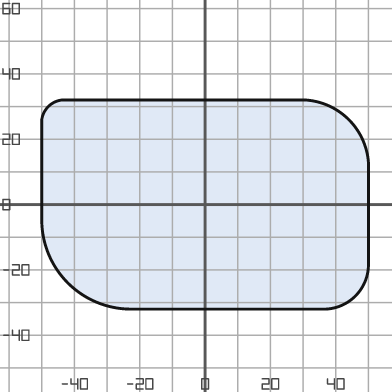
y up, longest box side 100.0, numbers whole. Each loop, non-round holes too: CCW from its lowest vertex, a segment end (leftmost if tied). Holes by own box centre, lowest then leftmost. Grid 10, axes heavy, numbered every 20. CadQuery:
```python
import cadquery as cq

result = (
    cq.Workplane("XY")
    .moveTo(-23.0, -32.0)
    .lineTo(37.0, -32.0)
    .threePointArc((46.0, -28.0), (50.0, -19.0))
    .lineTo(50.0, 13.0)
    .threePointArc((44.0, 26.0), (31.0, 32.0))
    .lineTo(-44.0, 32.0)
    .threePointArc((-48.0, 30.0), (-50.0, 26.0))
    .lineTo(-50.0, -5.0)
    .threePointArc((-42.0, -24.0), (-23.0, -32.0))
    .close()
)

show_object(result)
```